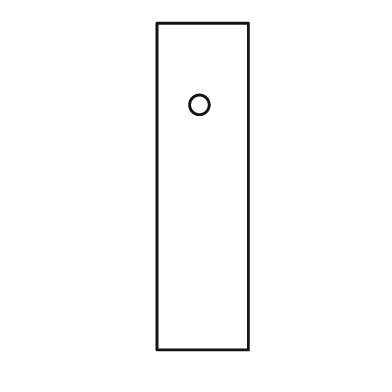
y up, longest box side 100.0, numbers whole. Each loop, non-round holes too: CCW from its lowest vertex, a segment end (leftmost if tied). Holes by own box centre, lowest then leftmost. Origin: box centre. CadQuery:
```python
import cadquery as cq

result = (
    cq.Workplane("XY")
    .moveTo(-14.0, -50.0)
    .lineTo(14.0, -50.0)
    .lineTo(14.0, 50.0)
    .lineTo(-14.0, 50.0)
    .close()
    .moveTo(-1.0, 25.0)
    .circle(3.0)
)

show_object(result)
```